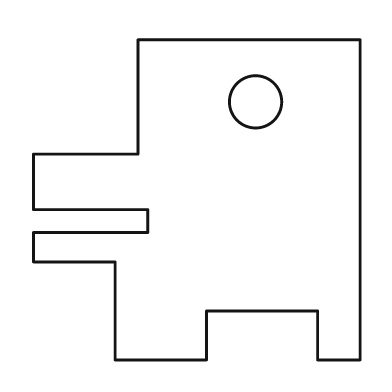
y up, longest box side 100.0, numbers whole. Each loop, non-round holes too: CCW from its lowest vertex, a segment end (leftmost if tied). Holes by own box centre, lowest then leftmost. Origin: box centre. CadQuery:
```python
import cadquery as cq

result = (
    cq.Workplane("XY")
    .moveTo(-25.0, -49.0)
    .lineTo(3.0, -49.0)
    .lineTo(3.0, -34.0)
    .lineTo(37.0, -34.0)
    .lineTo(37.0, -49.0)
    .lineTo(50.0, -49.0)
    .lineTo(50.0, 49.0)
    .lineTo(-18.0, 49.0)
    .lineTo(-18.0, 14.0)
    .lineTo(-50.0, 14.0)
    .lineTo(-50.0, -3.0)
    .lineTo(-15.0, -3.0)
    .lineTo(-15.0, -10.0)
    .lineTo(-50.0, -10.0)
    .lineTo(-50.0, -19.0)
    .lineTo(-25.0, -19.0)
    .close()
    .moveTo(18.0, 30.0)
    .circle(8.0)
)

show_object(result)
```